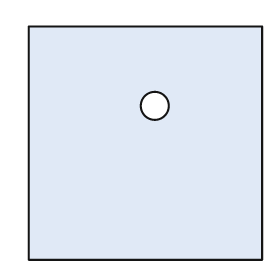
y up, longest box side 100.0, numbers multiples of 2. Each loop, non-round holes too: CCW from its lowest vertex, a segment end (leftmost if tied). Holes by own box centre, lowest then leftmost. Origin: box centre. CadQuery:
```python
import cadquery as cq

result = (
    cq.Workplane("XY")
    .moveTo(-50.0, -50.0)
    .lineTo(50.0, -50.0)
    .lineTo(50.0, 50.0)
    .lineTo(-50.0, 50.0)
    .close()
    .moveTo(4.0, 16.0)
    .circle(6.0)
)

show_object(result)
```